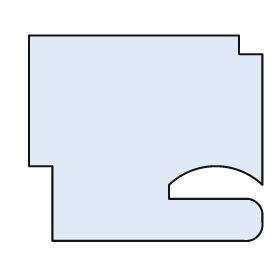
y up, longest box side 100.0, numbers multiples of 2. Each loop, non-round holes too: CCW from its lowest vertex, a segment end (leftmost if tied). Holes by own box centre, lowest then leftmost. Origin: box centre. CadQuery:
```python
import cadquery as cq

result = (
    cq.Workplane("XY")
    .moveTo(-40.0, -44.0)
    .lineTo(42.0, -44.0)
    .threePointArc((48.0, -42.0), (50.0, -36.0))
    .lineTo(50.0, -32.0)
    .threePointArc((48.0, -28.0), (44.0, -26.0))
    .lineTo(10.0, -26.0)
    .lineTo(10.0, -20.0)
    .threePointArc((30.0, -12.0), (50.0, -20.0))
    .lineTo(50.0, 36.0)
    .lineTo(40.0, 36.0)
    .lineTo(40.0, 44.0)
    .lineTo(-50.0, 44.0)
    .lineTo(-50.0, -12.0)
    .lineTo(-40.0, -12.0)
    .close()
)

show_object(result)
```